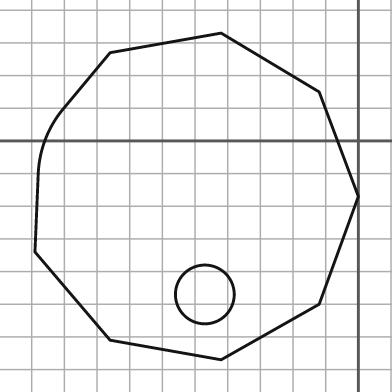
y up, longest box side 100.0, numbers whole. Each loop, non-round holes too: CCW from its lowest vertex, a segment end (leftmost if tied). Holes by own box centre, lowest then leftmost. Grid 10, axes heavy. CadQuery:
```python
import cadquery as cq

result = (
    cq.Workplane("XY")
    .moveTo(-42.0, -67.0)
    .lineTo(-12.0, -50.0)
    .lineTo(0.0, -17.0)
    .lineTo(-12.0, 15.0)
    .lineTo(-42.0, 33.0)
    .lineTo(-76.0, 27.0)
    .lineTo(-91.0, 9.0)
    .threePointArc((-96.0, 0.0), (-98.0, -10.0))
    .lineTo(-99.0, -34.0)
    .lineTo(-76.0, -61.0)
    .close()
    .moveTo(-47.0, -47.0)
    .circle(9.0)
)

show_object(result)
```